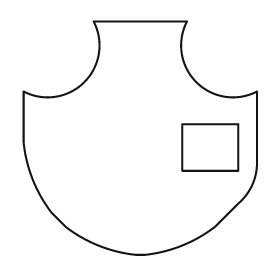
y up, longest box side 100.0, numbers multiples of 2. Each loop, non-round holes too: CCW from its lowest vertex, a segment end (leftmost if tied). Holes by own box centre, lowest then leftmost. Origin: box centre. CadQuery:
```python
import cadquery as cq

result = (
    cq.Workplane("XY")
    .moveTo(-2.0, -50.0)
    .lineTo(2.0, -50.0)
    .threePointArc((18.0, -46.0), (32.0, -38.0))
    .lineTo(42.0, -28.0)
    .threePointArc((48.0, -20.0), (50.0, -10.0))
    .lineTo(50.0, 20.0)
    .threePointArc((24.0, 24.0), (20.0, 50.0))
    .lineTo(-20.0, 50.0)
    .threePointArc((-24.0, 24.0), (-50.0, 20.0))
    .lineTo(-50.0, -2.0)
    .threePointArc((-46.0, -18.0), (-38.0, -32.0))
    .lineTo(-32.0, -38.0)
    .threePointArc((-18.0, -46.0), (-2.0, -50.0))
    .close()
    .moveTo(18.0, -14.0)
    .lineTo(42.0, -14.0)
    .lineTo(42.0, 6.0)
    .lineTo(18.0, 6.0)
    .close()
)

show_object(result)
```